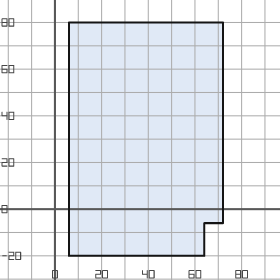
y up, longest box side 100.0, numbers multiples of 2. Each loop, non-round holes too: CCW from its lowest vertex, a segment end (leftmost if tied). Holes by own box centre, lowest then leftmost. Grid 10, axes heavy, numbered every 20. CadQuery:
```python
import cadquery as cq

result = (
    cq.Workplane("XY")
    .moveTo(6.0, -20.0)
    .lineTo(64.0, -20.0)
    .lineTo(64.0, -6.0)
    .lineTo(72.0, -6.0)
    .lineTo(72.0, 80.0)
    .lineTo(6.0, 80.0)
    .close()
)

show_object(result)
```